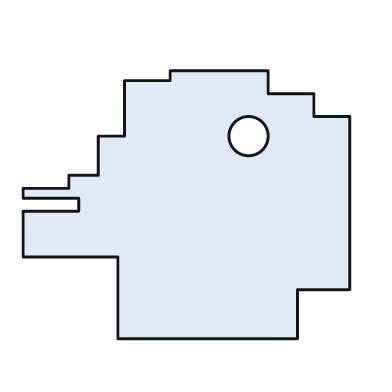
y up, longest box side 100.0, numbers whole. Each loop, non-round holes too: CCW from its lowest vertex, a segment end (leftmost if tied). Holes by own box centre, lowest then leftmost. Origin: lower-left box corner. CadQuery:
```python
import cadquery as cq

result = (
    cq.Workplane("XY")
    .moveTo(29.0, 0.0)
    .lineTo(84.0, 0.0)
    .lineTo(84.0, 15.0)
    .lineTo(100.0, 15.0)
    .lineTo(100.0, 68.0)
    .lineTo(89.0, 68.0)
    .lineTo(89.0, 75.0)
    .lineTo(75.0, 75.0)
    .lineTo(75.0, 82.0)
    .lineTo(45.0, 82.0)
    .lineTo(45.0, 79.0)
    .lineTo(31.0, 79.0)
    .lineTo(31.0, 62.0)
    .lineTo(23.0, 62.0)
    .lineTo(23.0, 50.0)
    .lineTo(14.0, 50.0)
    .lineTo(14.0, 46.0)
    .lineTo(0.0, 46.0)
    .lineTo(0.0, 43.0)
    .lineTo(17.0, 43.0)
    .lineTo(17.0, 39.0)
    .lineTo(0.0, 39.0)
    .lineTo(0.0, 25.0)
    .lineTo(29.0, 25.0)
    .close()
    .moveTo(69.0, 62.0)
    .circle(6.0)
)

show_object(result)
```